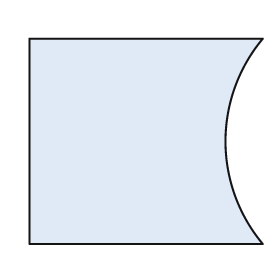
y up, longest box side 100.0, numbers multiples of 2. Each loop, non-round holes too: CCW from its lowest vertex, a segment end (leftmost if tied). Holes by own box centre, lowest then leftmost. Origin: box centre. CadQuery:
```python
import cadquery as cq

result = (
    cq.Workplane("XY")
    .moveTo(-50.0, -44.0)
    .lineTo(50.0, -44.0)
    .threePointArc((34.0, 0.0), (50.0, 44.0))
    .lineTo(-50.0, 44.0)
    .close()
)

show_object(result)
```